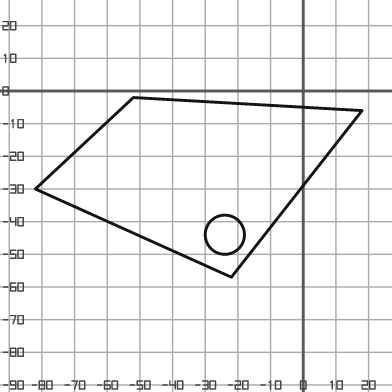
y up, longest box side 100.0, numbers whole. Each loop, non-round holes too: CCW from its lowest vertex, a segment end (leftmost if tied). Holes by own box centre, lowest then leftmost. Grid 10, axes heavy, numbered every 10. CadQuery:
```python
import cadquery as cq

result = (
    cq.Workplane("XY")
    .moveTo(-22.0, -57.0)
    .lineTo(18.0, -6.0)
    .lineTo(-52.0, -2.0)
    .lineTo(-82.0, -30.0)
    .close()
    .moveTo(-24.0, -44.0)
    .circle(6.0)
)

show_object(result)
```